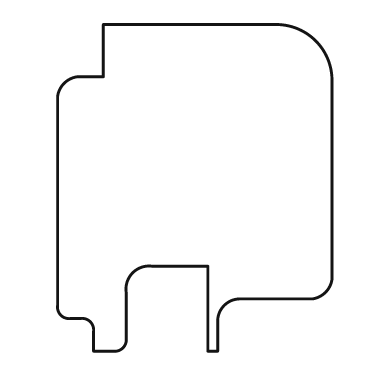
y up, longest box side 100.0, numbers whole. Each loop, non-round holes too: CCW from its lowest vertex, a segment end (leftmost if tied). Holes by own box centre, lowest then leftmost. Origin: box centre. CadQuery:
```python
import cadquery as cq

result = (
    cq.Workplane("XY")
    .moveTo(-31.0, -50.0)
    .lineTo(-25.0, -50.0)
    .threePointArc((-22.0, -49.0), (-21.0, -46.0))
    .lineTo(-21.0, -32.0)
    .threePointArc((-19.0, -26.0), (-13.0, -24.0))
    .lineTo(4.0, -24.0)
    .lineTo(4.0, -50.0)
    .lineTo(7.0, -50.0)
    .lineTo(7.0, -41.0)
    .threePointArc((9.0, -36.0), (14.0, -34.0))
    .lineTo(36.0, -34.0)
    .threePointArc((40.0, -32.0), (42.0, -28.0))
    .lineTo(42.0, 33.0)
    .threePointArc((37.0, 45.0), (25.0, 50.0))
    .lineTo(-28.0, 50.0)
    .lineTo(-28.0, 34.0)
    .lineTo(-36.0, 34.0)
    .threePointArc((-40.0, 32.0), (-42.0, 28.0))
    .lineTo(-42.0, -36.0)
    .threePointArc((-41.0, -39.0), (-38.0, -40.0))
    .lineTo(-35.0, -40.0)
    .threePointArc((-32.0, -41.0), (-31.0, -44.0))
    .close()
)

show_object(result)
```